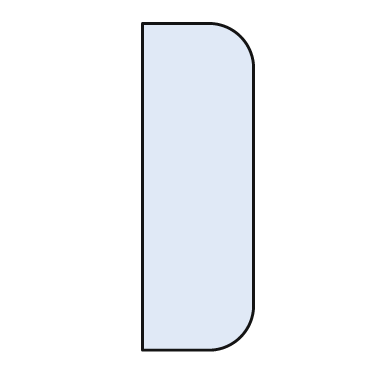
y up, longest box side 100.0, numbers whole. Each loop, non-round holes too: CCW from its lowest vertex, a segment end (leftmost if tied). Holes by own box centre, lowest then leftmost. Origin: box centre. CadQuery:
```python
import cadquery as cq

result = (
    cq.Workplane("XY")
    .moveTo(-17.0, -50.0)
    .lineTo(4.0, -50.0)
    .threePointArc((13.0, -46.0), (17.0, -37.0))
    .lineTo(17.0, 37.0)
    .threePointArc((13.0, 46.0), (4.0, 50.0))
    .lineTo(-17.0, 50.0)
    .close()
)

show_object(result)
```